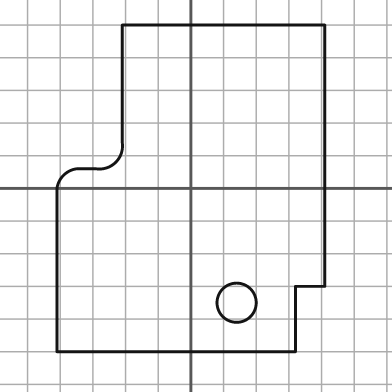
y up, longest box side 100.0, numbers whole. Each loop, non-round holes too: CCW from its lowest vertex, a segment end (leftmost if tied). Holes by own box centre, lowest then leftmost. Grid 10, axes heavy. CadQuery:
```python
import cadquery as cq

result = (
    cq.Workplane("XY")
    .moveTo(-41.0, -50.0)
    .lineTo(32.0, -50.0)
    .lineTo(32.0, -30.0)
    .lineTo(41.0, -30.0)
    .lineTo(41.0, 50.0)
    .lineTo(-21.0, 50.0)
    .lineTo(-21.0, 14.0)
    .threePointArc((-23.0, 8.0), (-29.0, 6.0))
    .lineTo(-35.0, 6.0)
    .threePointArc((-39.0, 4.0), (-41.0, 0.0))
    .close()
    .moveTo(14.0, -35.0)
    .circle(6.0)
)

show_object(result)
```